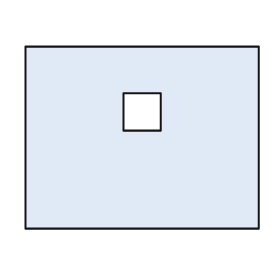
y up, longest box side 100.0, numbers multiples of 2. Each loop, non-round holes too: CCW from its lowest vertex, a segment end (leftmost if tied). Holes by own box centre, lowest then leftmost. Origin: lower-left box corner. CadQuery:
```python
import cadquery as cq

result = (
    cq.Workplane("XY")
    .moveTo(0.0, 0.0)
    .lineTo(100.0, 0.0)
    .lineTo(100.0, 78.0)
    .lineTo(0.0, 78.0)
    .close()
    .moveTo(42.0, 42.0)
    .lineTo(58.0, 42.0)
    .lineTo(58.0, 58.0)
    .lineTo(42.0, 58.0)
    .close()
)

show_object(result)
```